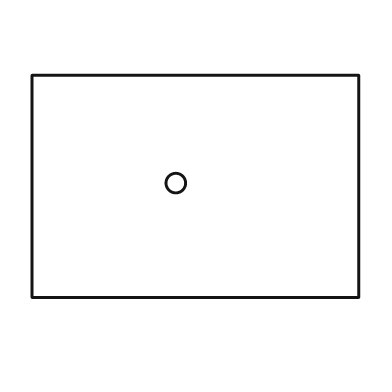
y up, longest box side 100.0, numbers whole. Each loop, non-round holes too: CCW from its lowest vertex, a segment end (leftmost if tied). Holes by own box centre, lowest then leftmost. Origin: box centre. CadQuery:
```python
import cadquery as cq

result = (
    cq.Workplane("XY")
    .moveTo(-50.0, -34.0)
    .lineTo(50.0, -34.0)
    .lineTo(50.0, 34.0)
    .lineTo(-50.0, 34.0)
    .close()
    .moveTo(-6.0, 1.0)
    .circle(3.0)
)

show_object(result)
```